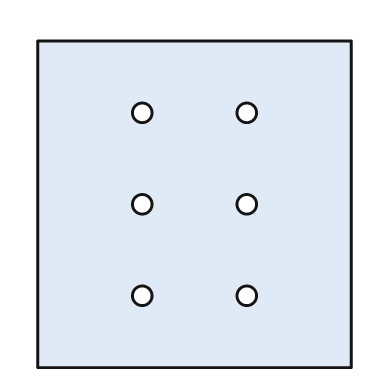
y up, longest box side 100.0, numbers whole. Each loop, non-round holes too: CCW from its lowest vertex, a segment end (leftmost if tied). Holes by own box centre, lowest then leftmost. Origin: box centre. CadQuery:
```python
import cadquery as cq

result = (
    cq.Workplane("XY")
    .moveTo(-48.0, -50.0)
    .lineTo(48.0, -50.0)
    .lineTo(48.0, 50.0)
    .lineTo(-48.0, 50.0)
    .close()
    .moveTo(-16.0, -28.0)
    .circle(3.0)
    .moveTo(16.0, -28.0)
    .circle(3.0)
    .moveTo(-16.0, 0.0)
    .circle(3.0)
    .moveTo(16.0, 0.0)
    .circle(3.0)
    .moveTo(-16.0, 28.0)
    .circle(3.0)
    .moveTo(16.0, 28.0)
    .circle(3.0)
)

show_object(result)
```